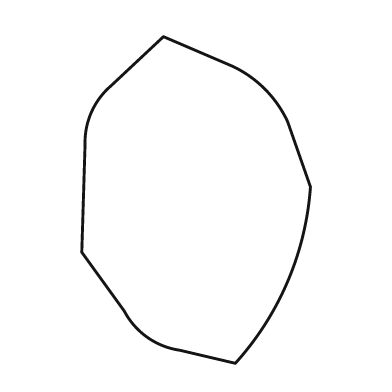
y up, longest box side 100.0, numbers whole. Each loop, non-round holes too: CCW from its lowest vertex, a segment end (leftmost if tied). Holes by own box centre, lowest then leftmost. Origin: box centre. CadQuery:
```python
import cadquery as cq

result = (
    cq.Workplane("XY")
    .moveTo(12.0, -50.0)
    .threePointArc((28.0, -25.0), (35.0, 4.0))
    .lineTo(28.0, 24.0)
    .threePointArc((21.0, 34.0), (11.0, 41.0))
    .lineTo(-10.0, 50.0)
    .lineTo(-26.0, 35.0)
    .threePointArc((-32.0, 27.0), (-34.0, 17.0))
    .lineTo(-35.0, -16.0)
    .lineTo(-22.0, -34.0)
    .threePointArc((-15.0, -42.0), (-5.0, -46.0))
    .close()
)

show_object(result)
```